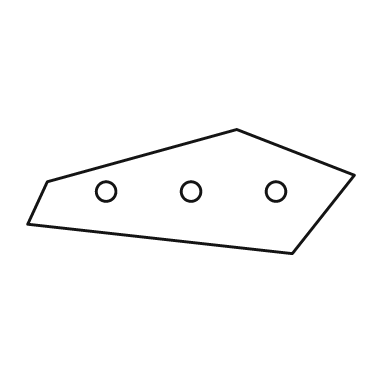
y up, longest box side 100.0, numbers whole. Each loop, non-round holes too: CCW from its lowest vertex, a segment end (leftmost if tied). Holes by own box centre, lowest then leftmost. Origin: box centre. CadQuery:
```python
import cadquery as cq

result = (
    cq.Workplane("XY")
    .moveTo(31.0, -19.0)
    .lineTo(50.0, 5.0)
    .lineTo(14.0, 19.0)
    .lineTo(-44.0, 3.0)
    .lineTo(-50.0, -10.0)
    .close()
    .moveTo(-26.0, 0.0)
    .circle(3.0)
    .moveTo(0.0, 0.0)
    .circle(3.0)
    .moveTo(26.0, 0.0)
    .circle(3.0)
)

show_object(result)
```